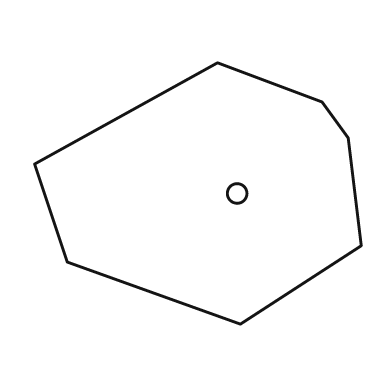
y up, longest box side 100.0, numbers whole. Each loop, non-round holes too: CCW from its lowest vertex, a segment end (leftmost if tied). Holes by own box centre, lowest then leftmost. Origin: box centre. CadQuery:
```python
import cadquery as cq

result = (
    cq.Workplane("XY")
    .moveTo(13.0, -40.0)
    .lineTo(50.0, -16.0)
    .lineTo(46.0, 17.0)
    .lineTo(38.0, 28.0)
    .lineTo(6.0, 40.0)
    .lineTo(-50.0, 9.0)
    .lineTo(-40.0, -21.0)
    .close()
    .moveTo(12.0, 0.0)
    .circle(3.0)
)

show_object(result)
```